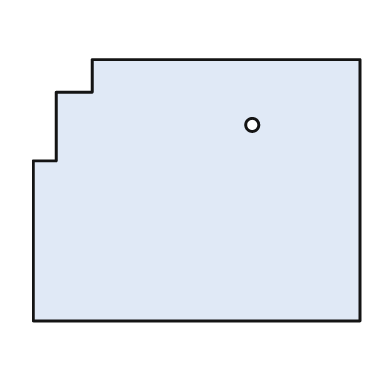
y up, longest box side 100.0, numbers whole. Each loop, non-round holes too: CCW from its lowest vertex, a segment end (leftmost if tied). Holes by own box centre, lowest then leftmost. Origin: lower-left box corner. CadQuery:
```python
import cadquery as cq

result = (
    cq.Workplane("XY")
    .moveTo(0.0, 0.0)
    .lineTo(100.0, 0.0)
    .lineTo(100.0, 80.0)
    .lineTo(18.0, 80.0)
    .lineTo(18.0, 70.0)
    .lineTo(7.0, 70.0)
    .lineTo(7.0, 49.0)
    .lineTo(0.0, 49.0)
    .close()
    .moveTo(67.0, 60.0)
    .circle(2.0)
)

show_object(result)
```